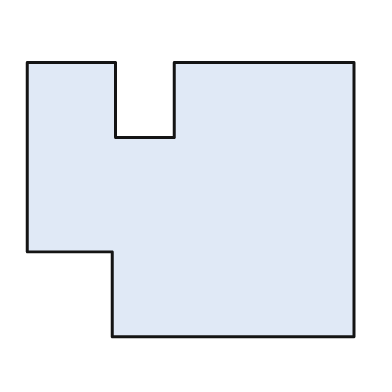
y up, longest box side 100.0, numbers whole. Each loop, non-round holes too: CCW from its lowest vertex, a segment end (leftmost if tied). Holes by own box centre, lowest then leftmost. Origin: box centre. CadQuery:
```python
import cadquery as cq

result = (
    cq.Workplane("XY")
    .moveTo(-24.0, -42.0)
    .lineTo(50.0, -42.0)
    .lineTo(50.0, 42.0)
    .lineTo(-5.0, 42.0)
    .lineTo(-5.0, 19.0)
    .lineTo(-23.0, 19.0)
    .lineTo(-23.0, 42.0)
    .lineTo(-50.0, 42.0)
    .lineTo(-50.0, -16.0)
    .lineTo(-24.0, -16.0)
    .close()
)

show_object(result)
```